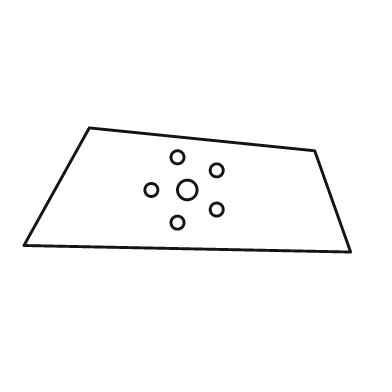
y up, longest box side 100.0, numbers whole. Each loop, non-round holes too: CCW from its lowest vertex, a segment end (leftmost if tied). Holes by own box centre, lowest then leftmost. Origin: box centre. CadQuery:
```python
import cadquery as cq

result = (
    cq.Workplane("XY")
    .moveTo(50.0, -19.0)
    .lineTo(39.0, 12.0)
    .lineTo(-30.0, 19.0)
    .lineTo(-50.0, -17.0)
    .close()
    .moveTo(-3.0, -10.0)
    .circle(2.0)
    .moveTo(9.0, -6.0)
    .circle(2.0)
    .moveTo(-11.0, 0.0)
    .circle(2.0)
    .moveTo(0.0, 0.0)
    .circle(3.0)
    .moveTo(9.0, 6.0)
    .circle(2.0)
    .moveTo(-3.0, 10.0)
    .circle(2.0)
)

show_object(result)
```